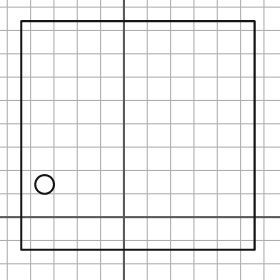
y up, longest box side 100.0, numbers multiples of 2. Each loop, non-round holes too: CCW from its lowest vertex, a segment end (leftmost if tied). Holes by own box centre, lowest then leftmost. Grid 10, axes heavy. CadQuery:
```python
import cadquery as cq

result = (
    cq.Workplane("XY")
    .moveTo(-44.0, -14.0)
    .lineTo(56.0, -14.0)
    .lineTo(56.0, 84.0)
    .lineTo(-44.0, 84.0)
    .close()
    .moveTo(-34.0, 14.0)
    .circle(4.0)
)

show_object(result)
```